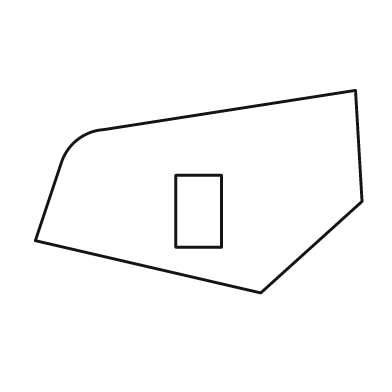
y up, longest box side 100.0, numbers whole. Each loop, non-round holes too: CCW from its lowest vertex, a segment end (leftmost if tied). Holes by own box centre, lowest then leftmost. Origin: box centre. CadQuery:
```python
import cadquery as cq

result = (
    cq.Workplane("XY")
    .moveTo(19.0, -31.0)
    .lineTo(50.0, -3.0)
    .lineTo(48.0, 31.0)
    .lineTo(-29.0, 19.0)
    .threePointArc((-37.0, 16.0), (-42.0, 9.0))
    .lineTo(-50.0, -15.0)
    .close()
    .moveTo(-7.0, -17.0)
    .lineTo(7.0, -17.0)
    .lineTo(7.0, 5.0)
    .lineTo(-7.0, 5.0)
    .close()
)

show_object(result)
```